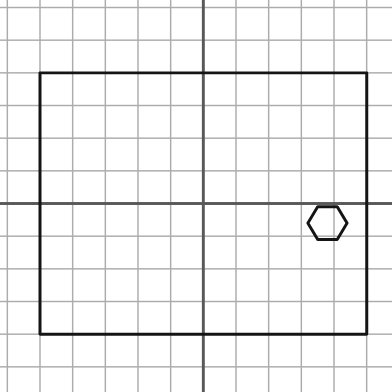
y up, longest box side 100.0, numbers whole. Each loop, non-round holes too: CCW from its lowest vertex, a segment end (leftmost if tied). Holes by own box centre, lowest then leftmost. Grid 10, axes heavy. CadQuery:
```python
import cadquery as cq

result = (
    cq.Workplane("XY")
    .moveTo(-50.0, -40.0)
    .lineTo(50.0, -40.0)
    .lineTo(50.0, 40.0)
    .lineTo(-50.0, 40.0)
    .close()
    .moveTo(35.0, -11.0)
    .lineTo(41.0, -11.0)
    .lineTo(44.0, -6.0)
    .lineTo(41.0, -1.0)
    .lineTo(35.0, -1.0)
    .lineTo(32.0, -6.0)
    .close()
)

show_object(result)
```